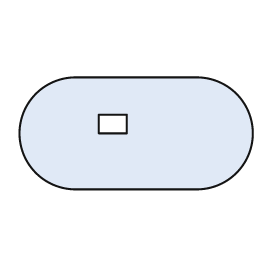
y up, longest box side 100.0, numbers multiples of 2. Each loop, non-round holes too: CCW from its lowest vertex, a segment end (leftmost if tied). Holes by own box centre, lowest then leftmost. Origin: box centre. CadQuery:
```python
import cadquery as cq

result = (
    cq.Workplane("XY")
    .moveTo(-26.0, -24.0)
    .lineTo(26.0, -24.0)
    .threePointArc((50.0, 0.0), (26.0, 24.0))
    .lineTo(-26.0, 24.0)
    .threePointArc((-50.0, 0.0), (-26.0, -24.0))
    .close()
    .moveTo(-16.0, 0.0)
    .lineTo(-4.0, 0.0)
    .lineTo(-4.0, 8.0)
    .lineTo(-16.0, 8.0)
    .close()
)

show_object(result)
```